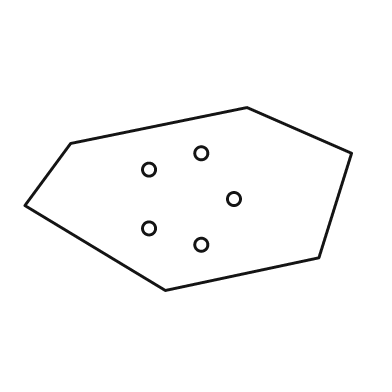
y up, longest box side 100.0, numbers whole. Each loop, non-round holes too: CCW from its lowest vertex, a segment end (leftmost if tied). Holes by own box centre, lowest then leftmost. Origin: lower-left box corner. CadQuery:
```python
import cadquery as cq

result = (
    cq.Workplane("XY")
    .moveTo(43.0, 0.0)
    .lineTo(90.0, 10.0)
    .lineTo(100.0, 42.0)
    .lineTo(68.0, 56.0)
    .lineTo(14.0, 45.0)
    .lineTo(0.0, 26.0)
    .close()
    .moveTo(54.0, 14.0)
    .circle(2.0)
    .moveTo(38.0, 19.0)
    .circle(2.0)
    .moveTo(64.0, 28.0)
    .circle(2.0)
    .moveTo(38.0, 37.0)
    .circle(2.0)
    .moveTo(54.0, 42.0)
    .circle(2.0)
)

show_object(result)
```